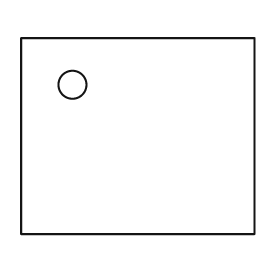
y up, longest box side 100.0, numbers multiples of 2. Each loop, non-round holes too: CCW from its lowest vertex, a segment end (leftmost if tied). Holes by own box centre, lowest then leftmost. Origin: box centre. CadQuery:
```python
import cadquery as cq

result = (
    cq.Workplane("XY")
    .moveTo(-50.0, -42.0)
    .lineTo(50.0, -42.0)
    .lineTo(50.0, 42.0)
    .lineTo(-50.0, 42.0)
    .close()
    .moveTo(-28.0, 22.0)
    .circle(6.0)
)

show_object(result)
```